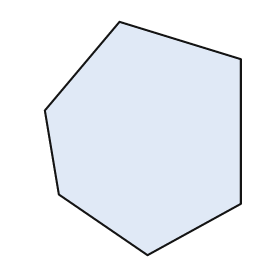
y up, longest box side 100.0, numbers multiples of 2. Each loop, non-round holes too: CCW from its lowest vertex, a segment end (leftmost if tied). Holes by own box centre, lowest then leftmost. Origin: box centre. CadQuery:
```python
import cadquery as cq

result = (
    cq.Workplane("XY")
    .moveTo(2.0, -50.0)
    .lineTo(42.0, -28.0)
    .lineTo(42.0, 34.0)
    .lineTo(-10.0, 50.0)
    .lineTo(-42.0, 12.0)
    .lineTo(-36.0, -24.0)
    .close()
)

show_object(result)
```